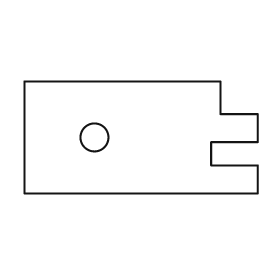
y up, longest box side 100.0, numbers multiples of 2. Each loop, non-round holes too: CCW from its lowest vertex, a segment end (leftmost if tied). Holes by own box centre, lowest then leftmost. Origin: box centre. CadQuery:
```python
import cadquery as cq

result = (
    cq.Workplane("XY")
    .moveTo(-50.0, -24.0)
    .lineTo(50.0, -24.0)
    .lineTo(50.0, -12.0)
    .lineTo(30.0, -12.0)
    .lineTo(30.0, -2.0)
    .lineTo(50.0, -2.0)
    .lineTo(50.0, 10.0)
    .lineTo(34.0, 10.0)
    .lineTo(34.0, 24.0)
    .lineTo(-50.0, 24.0)
    .close()
    .moveTo(-20.0, 0.0)
    .circle(6.0)
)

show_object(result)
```